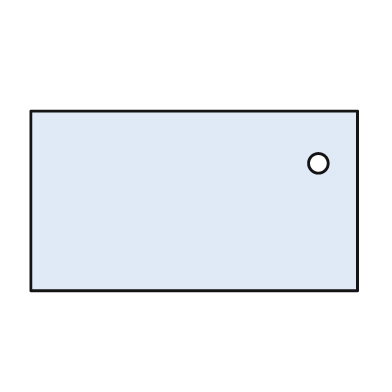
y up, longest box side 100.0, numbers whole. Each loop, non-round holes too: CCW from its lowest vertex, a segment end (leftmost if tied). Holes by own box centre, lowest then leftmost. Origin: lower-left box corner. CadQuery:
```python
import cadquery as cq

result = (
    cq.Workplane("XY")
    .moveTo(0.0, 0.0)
    .lineTo(100.0, 0.0)
    .lineTo(100.0, 55.0)
    .lineTo(0.0, 55.0)
    .close()
    .moveTo(88.0, 39.0)
    .circle(3.0)
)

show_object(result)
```